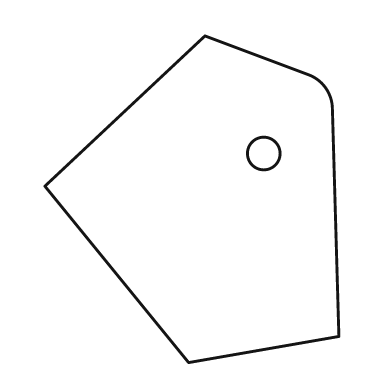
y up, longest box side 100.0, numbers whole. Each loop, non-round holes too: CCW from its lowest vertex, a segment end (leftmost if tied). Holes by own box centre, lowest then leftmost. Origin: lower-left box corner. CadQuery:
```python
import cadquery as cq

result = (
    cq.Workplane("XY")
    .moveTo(44.0, 0.0)
    .lineTo(90.0, 8.0)
    .lineTo(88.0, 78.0)
    .threePointArc((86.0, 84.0), (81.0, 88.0))
    .lineTo(49.0, 100.0)
    .lineTo(0.0, 54.0)
    .close()
    .moveTo(67.0, 64.0)
    .circle(5.0)
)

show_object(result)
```